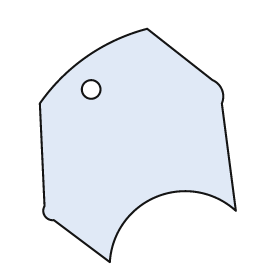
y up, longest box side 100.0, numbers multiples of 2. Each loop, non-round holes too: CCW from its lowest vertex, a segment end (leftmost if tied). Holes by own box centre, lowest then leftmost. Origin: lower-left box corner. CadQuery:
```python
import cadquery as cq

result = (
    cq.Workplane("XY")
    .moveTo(30.0, 0.0)
    .threePointArc((50.0, 28.0), (84.0, 22.0))
    .lineTo(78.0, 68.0)
    .threePointArc((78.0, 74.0), (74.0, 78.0))
    .lineTo(46.0, 100.0)
    .threePointArc((20.0, 88.0), (0.0, 68.0))
    .lineTo(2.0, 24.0)
    .threePointArc((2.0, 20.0), (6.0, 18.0))
    .close()
    .moveTo(22.0, 74.0)
    .circle(4.0)
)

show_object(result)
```